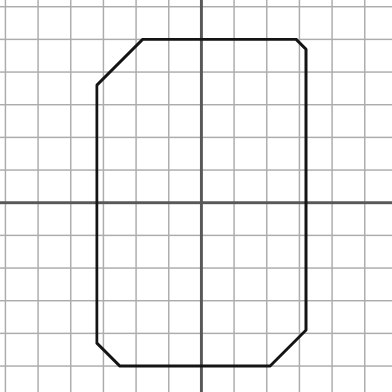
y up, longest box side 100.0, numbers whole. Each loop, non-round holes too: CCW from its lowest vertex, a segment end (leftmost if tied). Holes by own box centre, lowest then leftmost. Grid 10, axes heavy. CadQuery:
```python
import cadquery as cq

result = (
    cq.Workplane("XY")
    .moveTo(-25.0, -50.0)
    .lineTo(21.0, -50.0)
    .lineTo(32.0, -39.0)
    .lineTo(32.0, 47.0)
    .lineTo(29.0, 50.0)
    .lineTo(-18.0, 50.0)
    .lineTo(-32.0, 36.0)
    .lineTo(-32.0, -43.0)
    .close()
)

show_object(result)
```